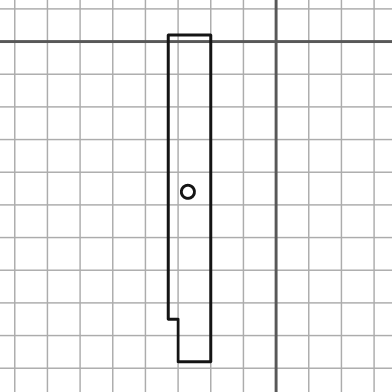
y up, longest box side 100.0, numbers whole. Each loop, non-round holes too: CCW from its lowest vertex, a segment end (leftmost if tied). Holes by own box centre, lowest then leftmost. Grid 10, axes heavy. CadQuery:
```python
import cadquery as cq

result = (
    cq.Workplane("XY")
    .moveTo(-30.0, -98.0)
    .lineTo(-20.0, -98.0)
    .lineTo(-20.0, 2.0)
    .lineTo(-33.0, 2.0)
    .lineTo(-33.0, -85.0)
    .lineTo(-30.0, -85.0)
    .close()
    .moveTo(-27.0, -46.0)
    .circle(2.0)
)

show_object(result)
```